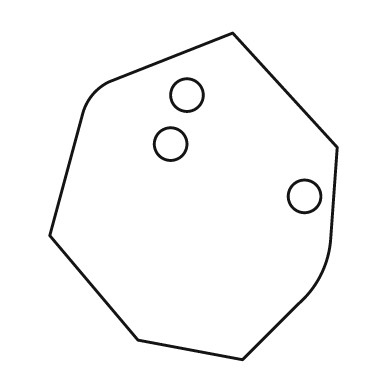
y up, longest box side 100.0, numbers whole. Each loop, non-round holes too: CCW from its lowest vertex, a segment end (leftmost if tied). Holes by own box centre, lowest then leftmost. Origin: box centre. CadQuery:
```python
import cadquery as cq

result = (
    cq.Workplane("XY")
    .moveTo(15.0, -50.0)
    .lineTo(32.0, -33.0)
    .threePointArc((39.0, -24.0), (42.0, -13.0))
    .lineTo(44.0, 15.0)
    .lineTo(12.0, 50.0)
    .lineTo(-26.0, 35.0)
    .threePointArc((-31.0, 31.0), (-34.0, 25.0))
    .lineTo(-44.0, -12.0)
    .lineTo(-17.0, -44.0)
    .close()
    .moveTo(34.0, 0.0)
    .circle(5.0)
    .moveTo(-7.0, 16.0)
    .circle(5.0)
    .moveTo(-2.0, 31.0)
    .circle(5.0)
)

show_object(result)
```